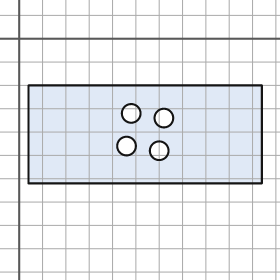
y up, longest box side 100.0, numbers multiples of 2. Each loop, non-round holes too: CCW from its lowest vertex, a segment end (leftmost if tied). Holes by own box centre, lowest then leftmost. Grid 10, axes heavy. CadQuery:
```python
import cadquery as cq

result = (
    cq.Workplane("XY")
    .moveTo(4.0, -62.0)
    .lineTo(104.0, -62.0)
    .lineTo(104.0, -20.0)
    .lineTo(4.0, -20.0)
    .close()
    .moveTo(60.0, -48.0)
    .circle(4.0)
    .moveTo(46.0, -46.0)
    .circle(4.0)
    .moveTo(62.0, -34.0)
    .circle(4.0)
    .moveTo(48.0, -32.0)
    .circle(4.0)
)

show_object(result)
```